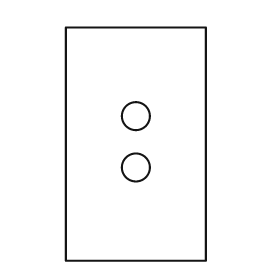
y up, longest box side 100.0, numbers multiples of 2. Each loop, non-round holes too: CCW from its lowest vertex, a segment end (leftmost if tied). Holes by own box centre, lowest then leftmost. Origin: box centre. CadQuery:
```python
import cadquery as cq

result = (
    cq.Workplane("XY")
    .moveTo(-30.0, -50.0)
    .lineTo(30.0, -50.0)
    .lineTo(30.0, 50.0)
    .lineTo(-30.0, 50.0)
    .close()
    .moveTo(0.0, -10.0)
    .circle(6.0)
    .moveTo(0.0, 12.0)
    .circle(6.0)
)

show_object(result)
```